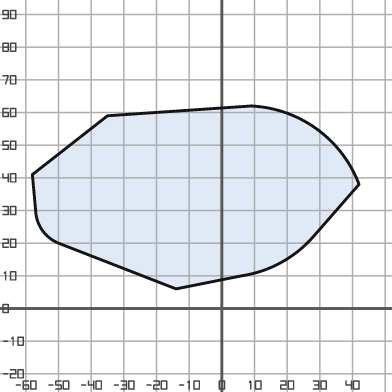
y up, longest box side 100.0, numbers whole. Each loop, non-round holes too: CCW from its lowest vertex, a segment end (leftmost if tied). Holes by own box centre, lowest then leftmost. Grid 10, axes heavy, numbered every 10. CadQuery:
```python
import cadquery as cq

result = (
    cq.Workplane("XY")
    .moveTo(-14.0, 6.0)
    .lineTo(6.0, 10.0)
    .threePointArc((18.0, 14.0), (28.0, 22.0))
    .lineTo(42.0, 38.0)
    .threePointArc((29.0, 55.0), (9.0, 62.0))
    .lineTo(-35.0, 59.0)
    .lineTo(-58.0, 41.0)
    .lineTo(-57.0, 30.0)
    .threePointArc((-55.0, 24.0), (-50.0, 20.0))
    .close()
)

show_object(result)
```